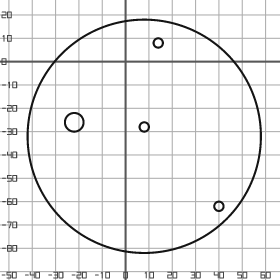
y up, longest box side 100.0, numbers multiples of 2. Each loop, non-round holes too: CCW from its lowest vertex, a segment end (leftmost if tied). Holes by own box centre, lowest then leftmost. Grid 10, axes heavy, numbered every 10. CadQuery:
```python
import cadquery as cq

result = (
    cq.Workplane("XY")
    .moveTo(8.0, -32.0)
    .circle(50.0)
    .moveTo(40.0, -62.0)
    .circle(2.0)
    .moveTo(8.0, -28.0)
    .circle(2.0)
    .moveTo(-22.0, -26.0)
    .circle(4.0)
    .moveTo(14.0, 8.0)
    .circle(2.0)
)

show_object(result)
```